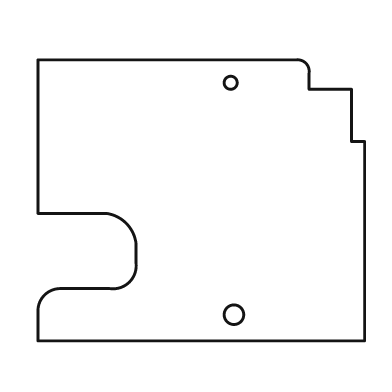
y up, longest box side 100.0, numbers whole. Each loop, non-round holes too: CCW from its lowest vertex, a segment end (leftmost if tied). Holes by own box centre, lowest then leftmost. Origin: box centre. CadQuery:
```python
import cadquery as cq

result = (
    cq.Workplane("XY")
    .moveTo(-50.0, -43.0)
    .lineTo(50.0, -43.0)
    .lineTo(50.0, 18.0)
    .lineTo(46.0, 18.0)
    .lineTo(46.0, 34.0)
    .lineTo(33.0, 34.0)
    .lineTo(33.0, 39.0)
    .threePointArc((32.0, 42.0), (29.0, 43.0))
    .lineTo(-50.0, 43.0)
    .lineTo(-50.0, -4.0)
    .lineTo(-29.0, -4.0)
    .threePointArc((-23.0, -7.0), (-20.0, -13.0))
    .lineTo(-20.0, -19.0)
    .threePointArc((-22.0, -25.0), (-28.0, -27.0))
    .lineTo(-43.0, -27.0)
    .threePointArc((-48.0, -29.0), (-50.0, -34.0))
    .close()
    .moveTo(10.0, -35.0)
    .circle(3.0)
    .moveTo(9.0, 36.0)
    .circle(2.0)
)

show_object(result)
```